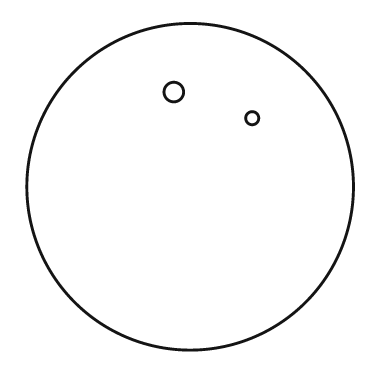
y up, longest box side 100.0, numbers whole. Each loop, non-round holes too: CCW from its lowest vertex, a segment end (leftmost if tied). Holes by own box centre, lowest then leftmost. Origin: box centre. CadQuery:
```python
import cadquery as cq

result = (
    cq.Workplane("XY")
    .moveTo(0.0, 0.0)
    .circle(50.0)
    .moveTo(19.0, 21.0)
    .circle(2.0)
    .moveTo(-5.0, 29.0)
    .circle(3.0)
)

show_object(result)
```